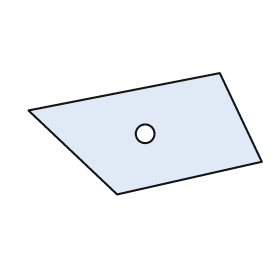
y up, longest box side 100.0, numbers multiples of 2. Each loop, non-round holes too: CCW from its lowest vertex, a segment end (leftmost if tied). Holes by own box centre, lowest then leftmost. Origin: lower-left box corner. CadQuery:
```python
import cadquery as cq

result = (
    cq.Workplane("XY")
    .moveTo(38.0, 0.0)
    .lineTo(100.0, 14.0)
    .lineTo(82.0, 52.0)
    .lineTo(0.0, 36.0)
    .close()
    .moveTo(50.0, 26.0)
    .circle(4.0)
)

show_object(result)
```